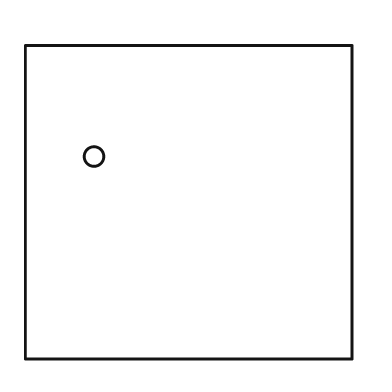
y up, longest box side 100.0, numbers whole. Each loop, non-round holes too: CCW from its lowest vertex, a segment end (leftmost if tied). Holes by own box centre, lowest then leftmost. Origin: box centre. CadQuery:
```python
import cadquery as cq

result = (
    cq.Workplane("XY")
    .moveTo(-50.0, -48.0)
    .lineTo(50.0, -48.0)
    .lineTo(50.0, 48.0)
    .lineTo(-50.0, 48.0)
    .close()
    .moveTo(-29.0, 14.0)
    .circle(3.0)
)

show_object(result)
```